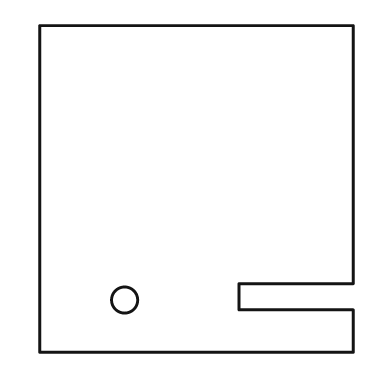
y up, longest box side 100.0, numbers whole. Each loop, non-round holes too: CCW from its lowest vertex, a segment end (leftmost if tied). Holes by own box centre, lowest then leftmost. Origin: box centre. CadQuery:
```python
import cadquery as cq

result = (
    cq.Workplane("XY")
    .moveTo(-48.0, -50.0)
    .lineTo(48.0, -50.0)
    .lineTo(48.0, -37.0)
    .lineTo(13.0, -37.0)
    .lineTo(13.0, -29.0)
    .lineTo(48.0, -29.0)
    .lineTo(48.0, 50.0)
    .lineTo(-48.0, 50.0)
    .close()
    .moveTo(-22.0, -34.0)
    .circle(4.0)
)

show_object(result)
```